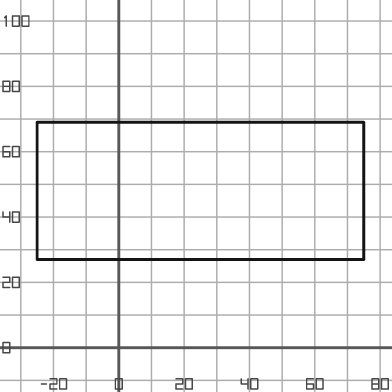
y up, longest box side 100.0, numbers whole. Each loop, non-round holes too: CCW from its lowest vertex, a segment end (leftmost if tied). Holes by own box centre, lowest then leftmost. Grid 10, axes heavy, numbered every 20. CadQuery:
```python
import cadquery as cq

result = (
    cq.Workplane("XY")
    .moveTo(-25.0, 27.0)
    .lineTo(75.0, 27.0)
    .lineTo(75.0, 69.0)
    .lineTo(-25.0, 69.0)
    .close()
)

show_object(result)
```